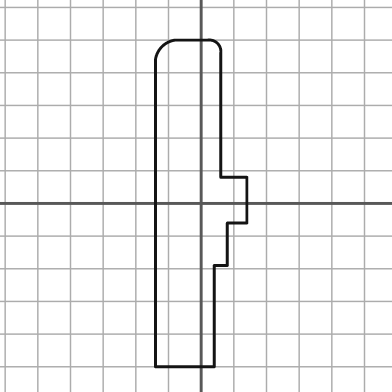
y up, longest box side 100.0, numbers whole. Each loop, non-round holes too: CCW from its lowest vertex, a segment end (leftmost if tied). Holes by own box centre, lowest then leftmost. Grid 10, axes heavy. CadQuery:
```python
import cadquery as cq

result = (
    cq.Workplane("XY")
    .moveTo(-14.0, -50.0)
    .lineTo(4.0, -50.0)
    .lineTo(4.0, -19.0)
    .lineTo(8.0, -19.0)
    .lineTo(8.0, -6.0)
    .lineTo(14.0, -6.0)
    .lineTo(14.0, 8.0)
    .lineTo(6.0, 8.0)
    .lineTo(6.0, 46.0)
    .threePointArc((5.0, 49.0), (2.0, 50.0))
    .lineTo(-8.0, 50.0)
    .threePointArc((-12.0, 48.0), (-14.0, 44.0))
    .close()
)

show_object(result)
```